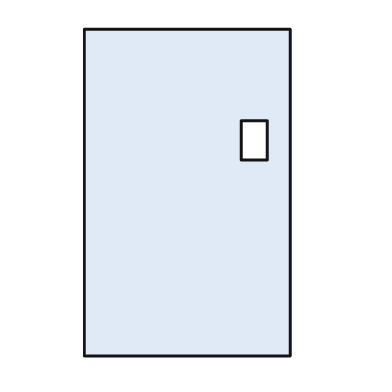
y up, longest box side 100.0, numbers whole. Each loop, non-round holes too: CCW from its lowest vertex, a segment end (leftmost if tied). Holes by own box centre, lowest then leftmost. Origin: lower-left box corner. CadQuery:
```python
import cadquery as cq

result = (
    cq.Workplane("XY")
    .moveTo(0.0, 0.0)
    .lineTo(63.0, 0.0)
    .lineTo(63.0, 100.0)
    .lineTo(0.0, 100.0)
    .close()
    .moveTo(48.0, 60.0)
    .lineTo(56.0, 60.0)
    .lineTo(56.0, 72.0)
    .lineTo(48.0, 72.0)
    .close()
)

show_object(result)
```